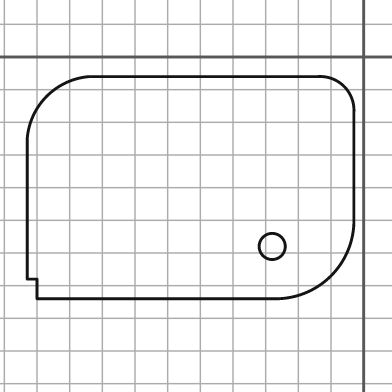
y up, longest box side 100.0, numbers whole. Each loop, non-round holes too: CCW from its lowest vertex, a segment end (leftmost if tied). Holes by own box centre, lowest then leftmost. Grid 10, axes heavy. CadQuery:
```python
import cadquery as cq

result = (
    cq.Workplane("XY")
    .moveTo(-100.0, -74.0)
    .lineTo(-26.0, -74.0)
    .threePointArc((-10.0, -67.0), (-3.0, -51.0))
    .lineTo(-3.0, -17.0)
    .threePointArc((-6.0, -9.0), (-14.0, -6.0))
    .lineTo(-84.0, -6.0)
    .threePointArc((-97.0, -12.0), (-103.0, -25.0))
    .lineTo(-103.0, -68.0)
    .lineTo(-100.0, -68.0)
    .close()
    .moveTo(-28.0, -58.0)
    .circle(4.0)
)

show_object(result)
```